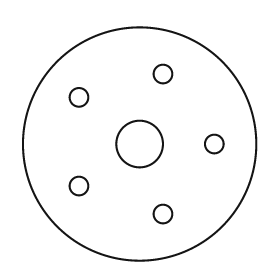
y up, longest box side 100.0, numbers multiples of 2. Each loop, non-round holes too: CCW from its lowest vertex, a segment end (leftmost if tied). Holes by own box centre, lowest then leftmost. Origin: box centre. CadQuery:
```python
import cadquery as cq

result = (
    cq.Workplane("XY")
    .moveTo(0.0, 0.0)
    .circle(50.0)
    .moveTo(10.0, -30.0)
    .circle(4.0)
    .moveTo(-26.0, -18.0)
    .circle(4.0)
    .moveTo(0.0, 0.0)
    .circle(10.0)
    .moveTo(32.0, 0.0)
    .circle(4.0)
    .moveTo(-26.0, 20.0)
    .circle(4.0)
    .moveTo(10.0, 30.0)
    .circle(4.0)
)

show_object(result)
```